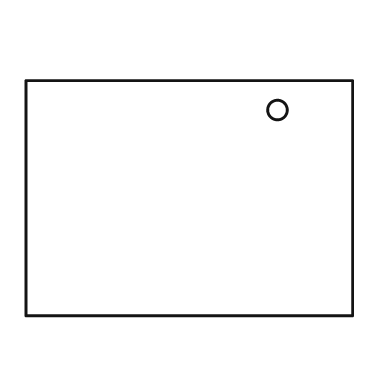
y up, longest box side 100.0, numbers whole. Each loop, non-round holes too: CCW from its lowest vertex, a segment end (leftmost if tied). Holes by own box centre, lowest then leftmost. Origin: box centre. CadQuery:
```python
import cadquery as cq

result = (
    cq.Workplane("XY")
    .moveTo(-50.0, -36.0)
    .lineTo(50.0, -36.0)
    .lineTo(50.0, 36.0)
    .lineTo(-50.0, 36.0)
    .close()
    .moveTo(27.0, 27.0)
    .circle(3.0)
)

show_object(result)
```